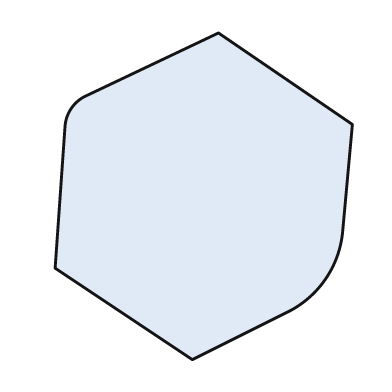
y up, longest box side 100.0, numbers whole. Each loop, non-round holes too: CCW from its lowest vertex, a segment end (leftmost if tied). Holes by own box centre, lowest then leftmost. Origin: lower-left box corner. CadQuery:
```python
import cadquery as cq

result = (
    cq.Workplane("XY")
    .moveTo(42.0, 0.0)
    .lineTo(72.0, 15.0)
    .threePointArc((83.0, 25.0), (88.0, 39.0))
    .lineTo(91.0, 72.0)
    .lineTo(50.0, 100.0)
    .lineTo(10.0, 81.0)
    .threePointArc((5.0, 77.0), (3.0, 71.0))
    .lineTo(0.0, 28.0)
    .close()
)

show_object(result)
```